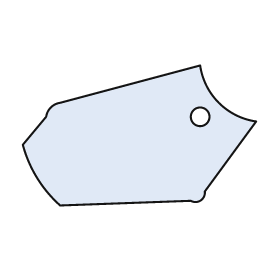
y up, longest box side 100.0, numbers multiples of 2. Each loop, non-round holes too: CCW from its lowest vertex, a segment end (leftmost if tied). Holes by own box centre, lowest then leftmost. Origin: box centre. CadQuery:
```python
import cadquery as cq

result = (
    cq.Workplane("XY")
    .moveTo(-34.0, -30.0)
    .lineTo(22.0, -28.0)
    .threePointArc((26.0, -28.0), (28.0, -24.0))
    .lineTo(50.0, 6.0)
    .threePointArc((34.0, 14.0), (26.0, 30.0))
    .lineTo(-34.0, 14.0)
    .threePointArc((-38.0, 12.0), (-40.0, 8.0))
    .lineTo(-50.0, -4.0)
    .threePointArc((-44.0, -18.0), (-34.0, -30.0))
    .close()
    .moveTo(26.0, 8.0)
    .circle(4.0)
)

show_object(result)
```